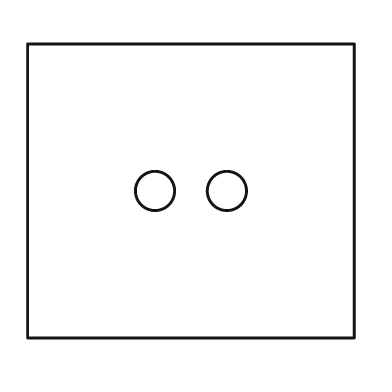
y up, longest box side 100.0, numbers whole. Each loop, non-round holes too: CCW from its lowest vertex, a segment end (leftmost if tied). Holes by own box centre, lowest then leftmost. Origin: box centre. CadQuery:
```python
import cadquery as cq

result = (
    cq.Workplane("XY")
    .moveTo(-50.0, -45.0)
    .lineTo(50.0, -45.0)
    .lineTo(50.0, 45.0)
    .lineTo(-50.0, 45.0)
    .close()
    .moveTo(-11.0, 0.0)
    .circle(6.0)
    .moveTo(11.0, 0.0)
    .circle(6.0)
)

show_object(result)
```